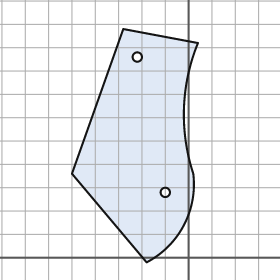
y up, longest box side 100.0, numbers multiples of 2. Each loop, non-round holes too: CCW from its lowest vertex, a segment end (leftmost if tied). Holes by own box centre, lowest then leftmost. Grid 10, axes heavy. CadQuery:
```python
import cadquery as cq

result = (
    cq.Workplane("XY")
    .moveTo(-18.0, -2.0)
    .threePointArc((-2.0, 14.0), (2.0, 36.0))
    .threePointArc((-2.0, 64.0), (4.0, 92.0))
    .lineTo(-28.0, 98.0)
    .lineTo(-50.0, 36.0)
    .close()
    .moveTo(-10.0, 28.0)
    .circle(2.0)
    .moveTo(-22.0, 86.0)
    .circle(2.0)
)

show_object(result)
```